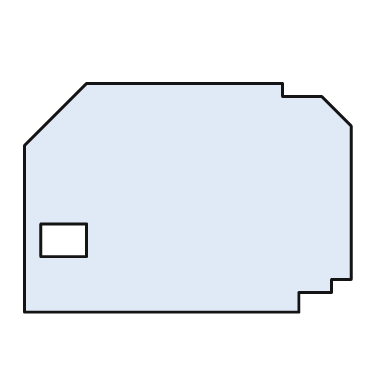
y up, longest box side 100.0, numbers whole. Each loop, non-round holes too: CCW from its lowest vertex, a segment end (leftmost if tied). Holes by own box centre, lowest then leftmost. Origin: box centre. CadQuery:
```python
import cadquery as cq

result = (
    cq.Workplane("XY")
    .moveTo(-50.0, -35.0)
    .lineTo(34.0, -35.0)
    .lineTo(34.0, -29.0)
    .lineTo(44.0, -29.0)
    .lineTo(44.0, -25.0)
    .lineTo(50.0, -25.0)
    .lineTo(50.0, 22.0)
    .lineTo(41.0, 31.0)
    .lineTo(29.0, 31.0)
    .lineTo(29.0, 35.0)
    .lineTo(-31.0, 35.0)
    .lineTo(-50.0, 16.0)
    .close()
    .moveTo(-45.0, -18.0)
    .lineTo(-31.0, -18.0)
    .lineTo(-31.0, -8.0)
    .lineTo(-45.0, -8.0)
    .close()
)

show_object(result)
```